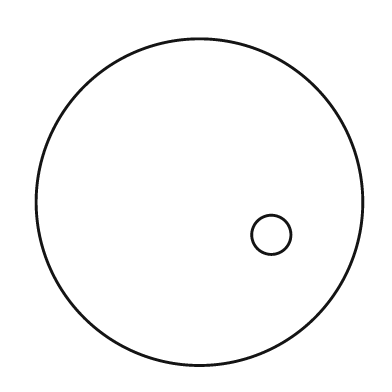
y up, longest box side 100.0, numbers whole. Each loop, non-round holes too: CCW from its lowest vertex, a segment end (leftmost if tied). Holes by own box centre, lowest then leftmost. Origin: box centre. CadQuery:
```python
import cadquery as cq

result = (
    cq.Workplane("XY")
    .moveTo(0.0, 0.0)
    .circle(50.0)
    .moveTo(22.0, -10.0)
    .circle(6.0)
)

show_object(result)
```